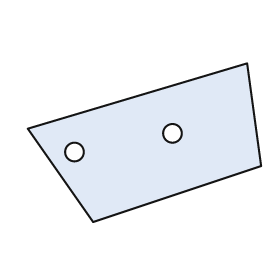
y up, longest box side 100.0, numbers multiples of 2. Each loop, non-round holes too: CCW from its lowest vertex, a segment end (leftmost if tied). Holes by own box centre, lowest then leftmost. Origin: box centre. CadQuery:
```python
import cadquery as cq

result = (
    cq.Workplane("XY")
    .moveTo(-22.0, -34.0)
    .lineTo(50.0, -10.0)
    .lineTo(44.0, 34.0)
    .lineTo(-50.0, 6.0)
    .close()
    .moveTo(-30.0, -4.0)
    .circle(4.0)
    .moveTo(12.0, 4.0)
    .circle(4.0)
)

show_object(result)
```